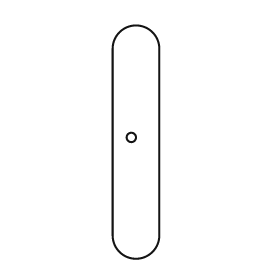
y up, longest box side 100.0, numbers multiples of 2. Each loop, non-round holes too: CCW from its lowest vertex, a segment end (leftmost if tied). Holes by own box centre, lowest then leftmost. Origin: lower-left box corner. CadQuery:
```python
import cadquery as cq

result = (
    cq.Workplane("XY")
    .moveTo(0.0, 10.0)
    .threePointArc((10.0, 0.0), (20.0, 10.0))
    .lineTo(20.0, 90.0)
    .threePointArc((10.0, 100.0), (0.0, 90.0))
    .close()
    .moveTo(8.0, 52.0)
    .circle(2.0)
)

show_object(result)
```